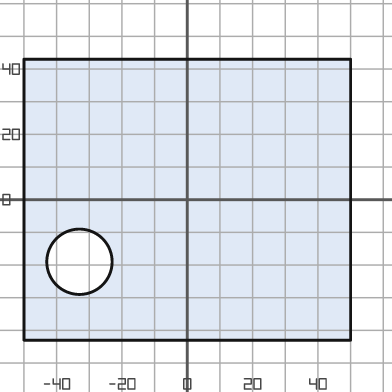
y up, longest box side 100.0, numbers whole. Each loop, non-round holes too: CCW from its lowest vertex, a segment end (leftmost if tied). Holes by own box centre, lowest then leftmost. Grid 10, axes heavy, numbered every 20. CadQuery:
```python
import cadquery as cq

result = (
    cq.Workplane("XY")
    .moveTo(-50.0, -43.0)
    .lineTo(50.0, -43.0)
    .lineTo(50.0, 43.0)
    .lineTo(-50.0, 43.0)
    .close()
    .moveTo(-33.0, -19.0)
    .circle(10.0)
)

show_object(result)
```